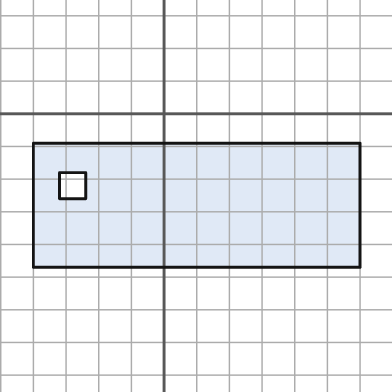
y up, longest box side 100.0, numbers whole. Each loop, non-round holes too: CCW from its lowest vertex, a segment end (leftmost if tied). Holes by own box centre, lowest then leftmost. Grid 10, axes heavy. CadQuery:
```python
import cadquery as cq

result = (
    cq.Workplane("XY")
    .moveTo(-40.0, -47.0)
    .lineTo(60.0, -47.0)
    .lineTo(60.0, -9.0)
    .lineTo(-40.0, -9.0)
    .close()
    .moveTo(-32.0, -26.0)
    .lineTo(-24.0, -26.0)
    .lineTo(-24.0, -18.0)
    .lineTo(-32.0, -18.0)
    .close()
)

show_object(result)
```